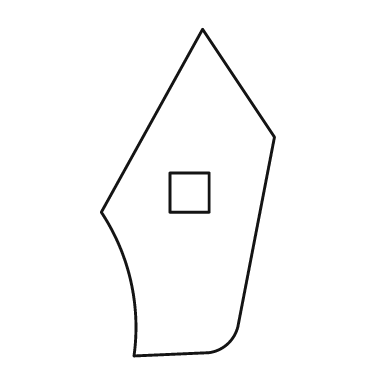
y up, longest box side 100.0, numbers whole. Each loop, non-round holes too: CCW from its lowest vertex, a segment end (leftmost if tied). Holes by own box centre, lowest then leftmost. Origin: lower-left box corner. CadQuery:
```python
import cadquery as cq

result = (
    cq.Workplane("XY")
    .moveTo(10.0, 0.0)
    .lineTo(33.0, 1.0)
    .threePointArc((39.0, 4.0), (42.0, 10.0))
    .lineTo(53.0, 67.0)
    .lineTo(31.0, 100.0)
    .lineTo(0.0, 44.0)
    .threePointArc((9.0, 23.0), (10.0, 0.0))
    .close()
    .moveTo(21.0, 44.0)
    .lineTo(33.0, 44.0)
    .lineTo(33.0, 56.0)
    .lineTo(21.0, 56.0)
    .close()
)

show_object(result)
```